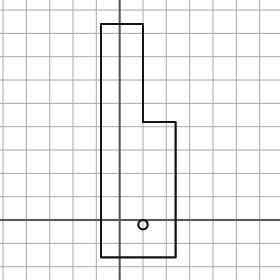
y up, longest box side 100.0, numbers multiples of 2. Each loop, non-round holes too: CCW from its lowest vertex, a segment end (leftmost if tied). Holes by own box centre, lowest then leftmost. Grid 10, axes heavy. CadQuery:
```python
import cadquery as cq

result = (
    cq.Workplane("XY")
    .moveTo(-8.0, -16.0)
    .lineTo(24.0, -16.0)
    .lineTo(24.0, 42.0)
    .lineTo(10.0, 42.0)
    .lineTo(10.0, 84.0)
    .lineTo(-8.0, 84.0)
    .close()
    .moveTo(10.0, -2.0)
    .circle(2.0)
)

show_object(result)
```